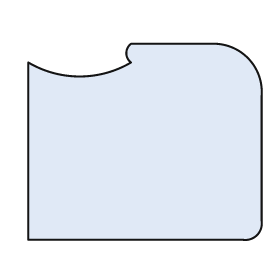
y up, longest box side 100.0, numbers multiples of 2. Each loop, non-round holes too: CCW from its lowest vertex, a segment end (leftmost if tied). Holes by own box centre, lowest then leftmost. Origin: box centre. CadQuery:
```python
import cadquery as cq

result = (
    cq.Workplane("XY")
    .moveTo(-50.0, -42.0)
    .lineTo(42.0, -42.0)
    .threePointArc((48.0, -40.0), (50.0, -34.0))
    .lineTo(50.0, 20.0)
    .threePointArc((44.0, 36.0), (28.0, 42.0))
    .lineTo(-6.0, 42.0)
    .threePointArc((-8.0, 38.0), (-6.0, 34.0))
    .threePointArc((-28.0, 28.0), (-50.0, 34.0))
    .close()
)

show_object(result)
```